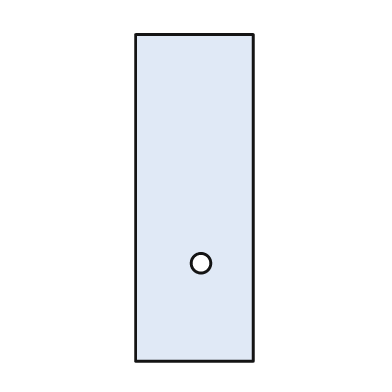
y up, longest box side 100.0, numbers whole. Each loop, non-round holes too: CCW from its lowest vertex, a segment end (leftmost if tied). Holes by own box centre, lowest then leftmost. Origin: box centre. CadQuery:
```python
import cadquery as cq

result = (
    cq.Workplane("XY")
    .moveTo(-18.0, -50.0)
    .lineTo(18.0, -50.0)
    .lineTo(18.0, 50.0)
    .lineTo(-18.0, 50.0)
    .close()
    .moveTo(2.0, -20.0)
    .circle(3.0)
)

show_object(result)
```